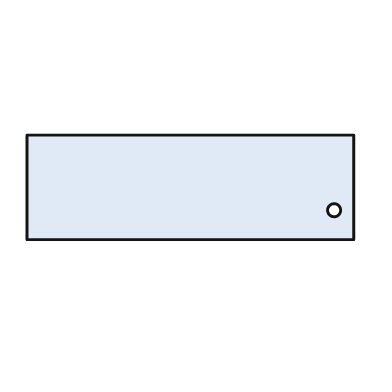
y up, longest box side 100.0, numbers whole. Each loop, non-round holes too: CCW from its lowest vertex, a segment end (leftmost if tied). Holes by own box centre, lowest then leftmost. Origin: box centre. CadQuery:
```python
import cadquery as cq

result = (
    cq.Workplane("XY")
    .moveTo(-50.0, -16.0)
    .lineTo(50.0, -16.0)
    .lineTo(50.0, 16.0)
    .lineTo(-50.0, 16.0)
    .close()
    .moveTo(44.0, -7.0)
    .circle(2.0)
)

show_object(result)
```